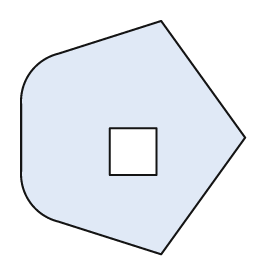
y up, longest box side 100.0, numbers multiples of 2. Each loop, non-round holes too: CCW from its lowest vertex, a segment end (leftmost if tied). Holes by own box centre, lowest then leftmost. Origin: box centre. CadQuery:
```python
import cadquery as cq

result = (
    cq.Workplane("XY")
    .moveTo(12.0, -50.0)
    .lineTo(48.0, 0.0)
    .lineTo(12.0, 50.0)
    .lineTo(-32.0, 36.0)
    .threePointArc((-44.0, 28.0), (-48.0, 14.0))
    .lineTo(-48.0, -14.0)
    .threePointArc((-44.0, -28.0), (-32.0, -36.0))
    .close()
    .moveTo(-10.0, -16.0)
    .lineTo(10.0, -16.0)
    .lineTo(10.0, 4.0)
    .lineTo(-10.0, 4.0)
    .close()
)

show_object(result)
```